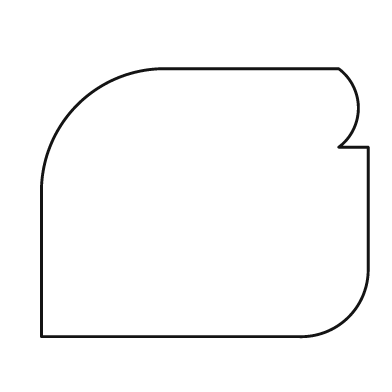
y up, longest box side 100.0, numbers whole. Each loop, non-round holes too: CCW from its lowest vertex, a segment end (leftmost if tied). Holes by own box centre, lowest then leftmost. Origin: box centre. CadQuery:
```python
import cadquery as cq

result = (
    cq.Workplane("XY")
    .moveTo(-50.0, -41.0)
    .lineTo(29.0, -41.0)
    .threePointArc((44.0, -35.0), (50.0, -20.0))
    .lineTo(50.0, 17.0)
    .lineTo(41.0, 17.0)
    .threePointArc((47.0, 29.0), (41.0, 41.0))
    .lineTo(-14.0, 41.0)
    .threePointArc((-39.0, 30.0), (-50.0, 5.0))
    .close()
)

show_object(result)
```